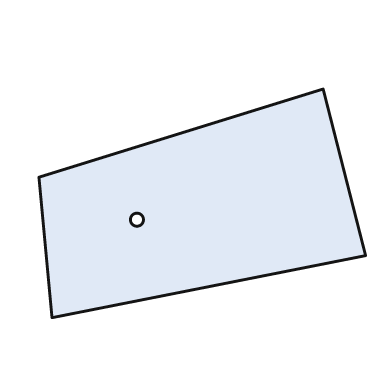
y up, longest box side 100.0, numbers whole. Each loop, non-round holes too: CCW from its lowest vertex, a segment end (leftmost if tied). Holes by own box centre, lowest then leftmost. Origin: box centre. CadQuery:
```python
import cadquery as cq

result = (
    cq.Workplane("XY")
    .moveTo(-46.0, -35.0)
    .lineTo(50.0, -16.0)
    .lineTo(37.0, 35.0)
    .lineTo(-50.0, 8.0)
    .close()
    .moveTo(-20.0, -5.0)
    .circle(2.0)
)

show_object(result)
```